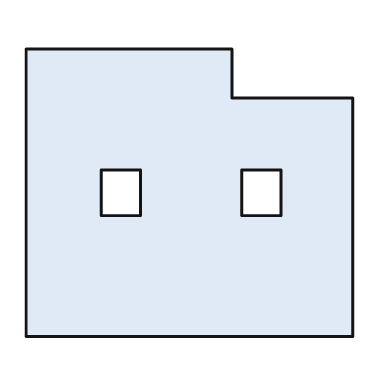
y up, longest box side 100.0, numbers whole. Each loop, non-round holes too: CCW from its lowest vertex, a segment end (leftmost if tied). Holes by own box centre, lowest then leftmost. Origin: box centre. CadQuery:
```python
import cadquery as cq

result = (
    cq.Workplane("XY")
    .moveTo(-50.0, -44.0)
    .lineTo(50.0, -44.0)
    .lineTo(50.0, 29.0)
    .lineTo(13.0, 29.0)
    .lineTo(13.0, 44.0)
    .lineTo(-50.0, 44.0)
    .close()
    .moveTo(-27.0, -7.0)
    .lineTo(-15.0, -7.0)
    .lineTo(-15.0, 7.0)
    .lineTo(-27.0, 7.0)
    .close()
    .moveTo(16.0, -7.0)
    .lineTo(28.0, -7.0)
    .lineTo(28.0, 7.0)
    .lineTo(16.0, 7.0)
    .close()
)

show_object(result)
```